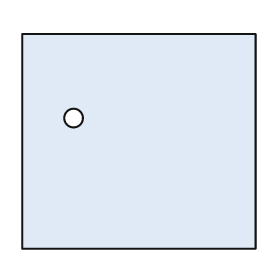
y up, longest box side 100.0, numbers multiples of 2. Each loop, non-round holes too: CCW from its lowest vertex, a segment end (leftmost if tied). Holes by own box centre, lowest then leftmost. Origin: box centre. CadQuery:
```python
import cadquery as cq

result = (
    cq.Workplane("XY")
    .moveTo(-50.0, -46.0)
    .lineTo(50.0, -46.0)
    .lineTo(50.0, 46.0)
    .lineTo(-50.0, 46.0)
    .close()
    .moveTo(-28.0, 10.0)
    .circle(4.0)
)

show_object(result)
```